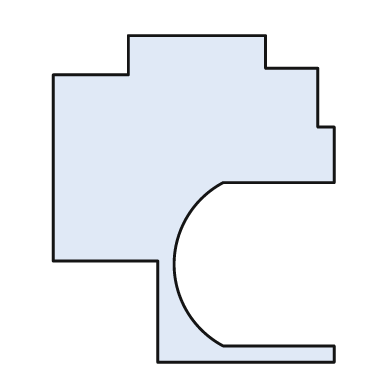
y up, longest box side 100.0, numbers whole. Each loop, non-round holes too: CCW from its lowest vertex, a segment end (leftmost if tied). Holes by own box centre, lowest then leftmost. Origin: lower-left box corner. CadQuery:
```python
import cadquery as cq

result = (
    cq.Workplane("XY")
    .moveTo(32.0, 0.0)
    .lineTo(86.0, 0.0)
    .lineTo(86.0, 5.0)
    .lineTo(52.0, 5.0)
    .threePointArc((37.0, 30.0), (52.0, 55.0))
    .lineTo(86.0, 55.0)
    .lineTo(86.0, 72.0)
    .lineTo(81.0, 72.0)
    .lineTo(81.0, 90.0)
    .lineTo(65.0, 90.0)
    .lineTo(65.0, 100.0)
    .lineTo(23.0, 100.0)
    .lineTo(23.0, 88.0)
    .lineTo(0.0, 88.0)
    .lineTo(0.0, 31.0)
    .lineTo(32.0, 31.0)
    .close()
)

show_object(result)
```